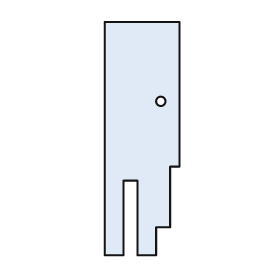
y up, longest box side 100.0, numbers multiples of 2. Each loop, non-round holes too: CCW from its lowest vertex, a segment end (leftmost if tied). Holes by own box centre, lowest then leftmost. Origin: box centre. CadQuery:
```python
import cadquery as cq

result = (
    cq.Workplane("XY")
    .moveTo(-16.0, -50.0)
    .lineTo(-8.0, -50.0)
    .lineTo(-8.0, -18.0)
    .lineTo(-2.0, -18.0)
    .lineTo(-2.0, -50.0)
    .lineTo(6.0, -50.0)
    .lineTo(6.0, -38.0)
    .lineTo(12.0, -38.0)
    .lineTo(12.0, -12.0)
    .lineTo(16.0, -12.0)
    .lineTo(16.0, 50.0)
    .lineTo(-16.0, 50.0)
    .close()
    .moveTo(8.0, 16.0)
    .circle(2.0)
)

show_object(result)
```